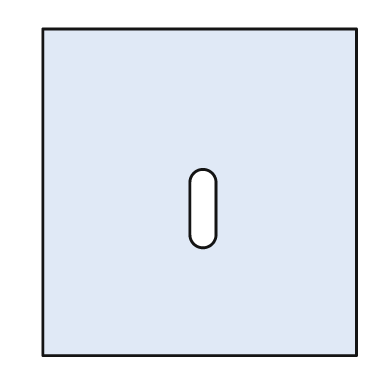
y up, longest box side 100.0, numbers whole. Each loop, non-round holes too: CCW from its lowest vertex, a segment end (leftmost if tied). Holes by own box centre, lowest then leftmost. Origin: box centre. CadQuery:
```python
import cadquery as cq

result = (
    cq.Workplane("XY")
    .moveTo(-48.0, -50.0)
    .lineTo(48.0, -50.0)
    .lineTo(48.0, 50.0)
    .lineTo(-48.0, 50.0)
    .close()
    .moveTo(-3.0, -13.0)
    .threePointArc((1.0, -17.0), (5.0, -13.0))
    .lineTo(5.0, 3.0)
    .threePointArc((1.0, 7.0), (-3.0, 3.0))
    .close()
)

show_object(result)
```